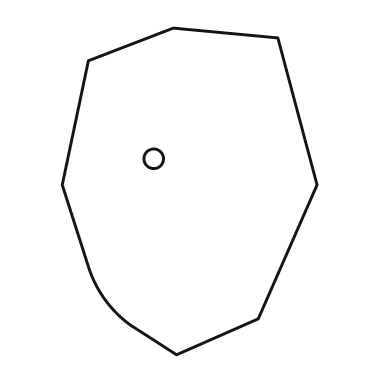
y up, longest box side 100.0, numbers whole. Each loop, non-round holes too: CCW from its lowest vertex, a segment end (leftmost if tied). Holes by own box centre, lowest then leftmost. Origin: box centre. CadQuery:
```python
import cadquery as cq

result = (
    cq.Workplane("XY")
    .moveTo(-4.0, -50.0)
    .lineTo(21.0, -39.0)
    .lineTo(39.0, 2.0)
    .lineTo(27.0, 47.0)
    .lineTo(-5.0, 50.0)
    .lineTo(-31.0, 40.0)
    .lineTo(-39.0, 2.0)
    .lineTo(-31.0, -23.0)
    .threePointArc((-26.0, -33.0), (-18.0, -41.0))
    .close()
    .moveTo(-11.0, 10.0)
    .circle(3.0)
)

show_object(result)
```